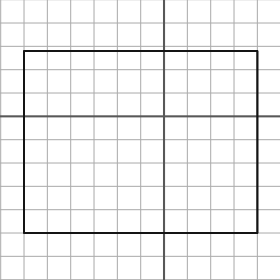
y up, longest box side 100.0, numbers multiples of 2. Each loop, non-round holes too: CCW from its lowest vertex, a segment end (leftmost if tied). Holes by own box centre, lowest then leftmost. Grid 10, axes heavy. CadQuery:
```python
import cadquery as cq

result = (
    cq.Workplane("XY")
    .moveTo(-60.0, -50.0)
    .lineTo(40.0, -50.0)
    .lineTo(40.0, 28.0)
    .lineTo(-60.0, 28.0)
    .close()
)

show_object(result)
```